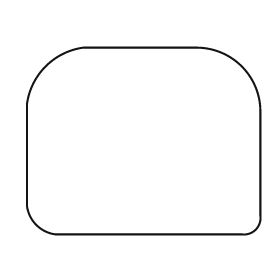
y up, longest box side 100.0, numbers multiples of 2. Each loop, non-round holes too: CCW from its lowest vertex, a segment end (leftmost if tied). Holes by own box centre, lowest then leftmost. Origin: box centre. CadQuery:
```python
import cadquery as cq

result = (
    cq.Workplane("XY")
    .moveTo(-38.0, -40.0)
    .lineTo(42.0, -40.0)
    .threePointArc((48.0, -38.0), (50.0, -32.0))
    .lineTo(50.0, 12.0)
    .threePointArc((42.0, 32.0), (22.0, 40.0))
    .lineTo(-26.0, 40.0)
    .threePointArc((-42.0, 32.0), (-50.0, 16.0))
    .lineTo(-50.0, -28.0)
    .threePointArc((-46.0, -36.0), (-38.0, -40.0))
    .close()
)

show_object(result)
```